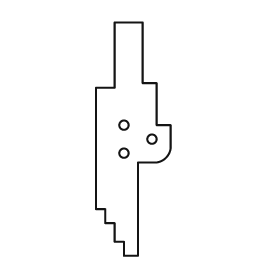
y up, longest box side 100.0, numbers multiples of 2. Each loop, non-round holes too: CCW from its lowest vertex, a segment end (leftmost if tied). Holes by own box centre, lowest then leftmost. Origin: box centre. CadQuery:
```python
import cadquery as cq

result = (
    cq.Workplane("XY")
    .moveTo(-4.0, -50.0)
    .lineTo(2.0, -50.0)
    .lineTo(2.0, -10.0)
    .lineTo(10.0, -10.0)
    .threePointArc((14.0, -8.0), (16.0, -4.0))
    .lineTo(16.0, 6.0)
    .lineTo(10.0, 6.0)
    .lineTo(10.0, 24.0)
    .lineTo(4.0, 24.0)
    .lineTo(4.0, 50.0)
    .lineTo(-8.0, 50.0)
    .lineTo(-8.0, 22.0)
    .lineTo(-16.0, 22.0)
    .lineTo(-16.0, -30.0)
    .lineTo(-12.0, -30.0)
    .lineTo(-12.0, -36.0)
    .lineTo(-8.0, -36.0)
    .lineTo(-8.0, -44.0)
    .lineTo(-4.0, -44.0)
    .close()
    .moveTo(-4.0, -6.0)
    .circle(2.0)
    .moveTo(8.0, 0.0)
    .circle(2.0)
    .moveTo(-4.0, 6.0)
    .circle(2.0)
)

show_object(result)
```